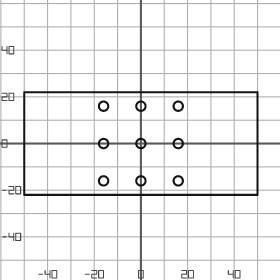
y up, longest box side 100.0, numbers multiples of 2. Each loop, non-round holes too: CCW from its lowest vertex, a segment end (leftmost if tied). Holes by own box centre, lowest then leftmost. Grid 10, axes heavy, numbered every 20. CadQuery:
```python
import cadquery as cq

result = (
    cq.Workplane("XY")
    .moveTo(-50.0, -22.0)
    .lineTo(50.0, -22.0)
    .lineTo(50.0, 22.0)
    .lineTo(-50.0, 22.0)
    .close()
    .moveTo(-16.0, -16.0)
    .circle(2.0)
    .moveTo(0.0, -16.0)
    .circle(2.0)
    .moveTo(16.0, -16.0)
    .circle(2.0)
    .moveTo(-16.0, 0.0)
    .circle(2.0)
    .moveTo(0.0, 0.0)
    .circle(2.0)
    .moveTo(16.0, 0.0)
    .circle(2.0)
    .moveTo(-16.0, 16.0)
    .circle(2.0)
    .moveTo(0.0, 16.0)
    .circle(2.0)
    .moveTo(16.0, 16.0)
    .circle(2.0)
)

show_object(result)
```